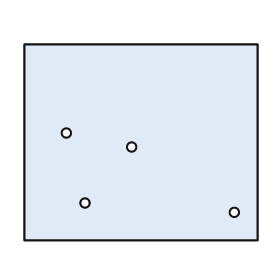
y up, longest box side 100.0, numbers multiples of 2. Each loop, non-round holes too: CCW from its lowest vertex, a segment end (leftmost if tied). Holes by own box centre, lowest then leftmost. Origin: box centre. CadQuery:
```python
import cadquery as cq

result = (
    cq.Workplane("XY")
    .moveTo(-50.0, -42.0)
    .lineTo(50.0, -42.0)
    .lineTo(50.0, 42.0)
    .lineTo(-50.0, 42.0)
    .close()
    .moveTo(40.0, -30.0)
    .circle(2.0)
    .moveTo(-24.0, -26.0)
    .circle(2.0)
    .moveTo(-4.0, -2.0)
    .circle(2.0)
    .moveTo(-32.0, 4.0)
    .circle(2.0)
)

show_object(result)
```